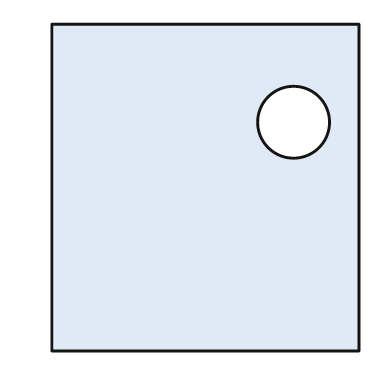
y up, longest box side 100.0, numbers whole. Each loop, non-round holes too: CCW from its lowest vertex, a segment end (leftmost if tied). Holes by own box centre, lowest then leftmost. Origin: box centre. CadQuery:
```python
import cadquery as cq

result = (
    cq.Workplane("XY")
    .moveTo(-47.0, -50.0)
    .lineTo(47.0, -50.0)
    .lineTo(47.0, 50.0)
    .lineTo(-47.0, 50.0)
    .close()
    .moveTo(27.0, 20.0)
    .circle(11.0)
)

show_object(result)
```